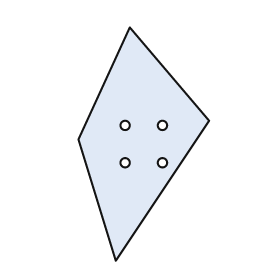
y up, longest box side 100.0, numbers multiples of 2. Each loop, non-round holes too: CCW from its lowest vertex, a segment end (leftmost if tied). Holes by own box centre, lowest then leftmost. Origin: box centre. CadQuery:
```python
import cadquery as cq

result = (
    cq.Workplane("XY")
    .moveTo(-12.0, -50.0)
    .lineTo(28.0, 10.0)
    .lineTo(-6.0, 50.0)
    .lineTo(-28.0, 2.0)
    .close()
    .moveTo(-8.0, -8.0)
    .circle(2.0)
    .moveTo(8.0, -8.0)
    .circle(2.0)
    .moveTo(-8.0, 8.0)
    .circle(2.0)
    .moveTo(8.0, 8.0)
    .circle(2.0)
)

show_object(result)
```